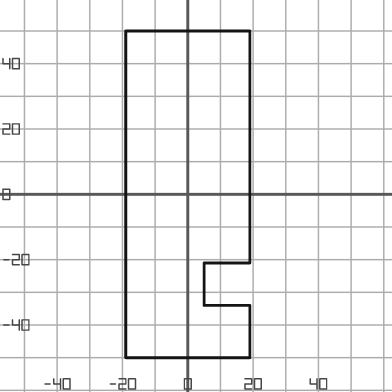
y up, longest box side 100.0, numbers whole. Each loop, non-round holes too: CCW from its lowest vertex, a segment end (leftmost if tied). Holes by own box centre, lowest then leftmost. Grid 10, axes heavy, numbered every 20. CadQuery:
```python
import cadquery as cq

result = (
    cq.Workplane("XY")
    .moveTo(-19.0, -50.0)
    .lineTo(19.0, -50.0)
    .lineTo(19.0, -34.0)
    .lineTo(5.0, -34.0)
    .lineTo(5.0, -21.0)
    .lineTo(19.0, -21.0)
    .lineTo(19.0, 50.0)
    .lineTo(-19.0, 50.0)
    .close()
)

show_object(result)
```